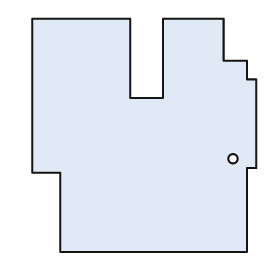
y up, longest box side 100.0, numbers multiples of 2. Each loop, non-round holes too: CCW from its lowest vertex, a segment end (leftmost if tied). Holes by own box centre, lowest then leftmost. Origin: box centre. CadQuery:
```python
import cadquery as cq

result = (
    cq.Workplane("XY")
    .moveTo(-36.0, -50.0)
    .lineTo(44.0, -50.0)
    .lineTo(44.0, -14.0)
    .lineTo(48.0, -14.0)
    .lineTo(48.0, 24.0)
    .lineTo(44.0, 24.0)
    .lineTo(44.0, 32.0)
    .lineTo(34.0, 32.0)
    .lineTo(34.0, 50.0)
    .lineTo(8.0, 50.0)
    .lineTo(8.0, 16.0)
    .lineTo(-6.0, 16.0)
    .lineTo(-6.0, 50.0)
    .lineTo(-48.0, 50.0)
    .lineTo(-48.0, -16.0)
    .lineTo(-36.0, -16.0)
    .close()
    .moveTo(38.0, -10.0)
    .circle(2.0)
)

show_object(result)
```